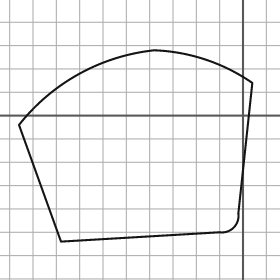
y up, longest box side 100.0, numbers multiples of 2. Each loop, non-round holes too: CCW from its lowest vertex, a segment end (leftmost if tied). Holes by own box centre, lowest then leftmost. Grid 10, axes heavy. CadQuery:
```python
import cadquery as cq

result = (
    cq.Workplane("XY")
    .moveTo(-78.0, -54.0)
    .lineTo(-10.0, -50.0)
    .threePointArc((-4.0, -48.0), (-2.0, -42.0))
    .lineTo(4.0, 14.0)
    .threePointArc((-16.0, 24.0), (-38.0, 28.0))
    .threePointArc((-70.0, 18.0), (-96.0, -4.0))
    .close()
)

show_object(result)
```